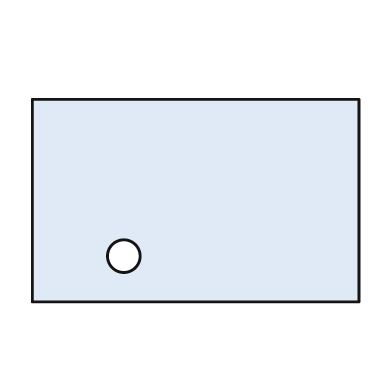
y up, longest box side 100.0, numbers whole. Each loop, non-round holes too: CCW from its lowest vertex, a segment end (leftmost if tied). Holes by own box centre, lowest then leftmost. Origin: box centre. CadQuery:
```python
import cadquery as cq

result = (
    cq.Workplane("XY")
    .moveTo(-50.0, -31.0)
    .lineTo(50.0, -31.0)
    .lineTo(50.0, 31.0)
    .lineTo(-50.0, 31.0)
    .close()
    .moveTo(-22.0, -17.0)
    .circle(5.0)
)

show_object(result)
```